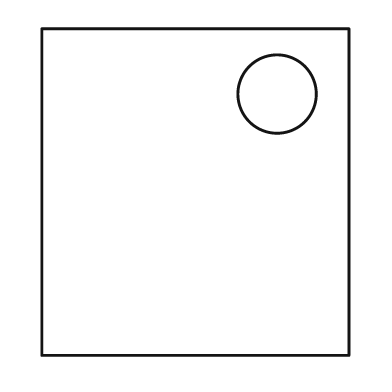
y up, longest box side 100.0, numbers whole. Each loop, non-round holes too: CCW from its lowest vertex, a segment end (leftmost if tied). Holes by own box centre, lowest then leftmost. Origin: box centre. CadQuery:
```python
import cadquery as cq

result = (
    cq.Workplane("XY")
    .moveTo(-47.0, -50.0)
    .lineTo(47.0, -50.0)
    .lineTo(47.0, 50.0)
    .lineTo(-47.0, 50.0)
    .close()
    .moveTo(25.0, 30.0)
    .circle(12.0)
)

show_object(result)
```